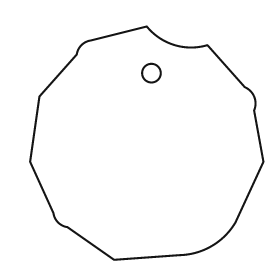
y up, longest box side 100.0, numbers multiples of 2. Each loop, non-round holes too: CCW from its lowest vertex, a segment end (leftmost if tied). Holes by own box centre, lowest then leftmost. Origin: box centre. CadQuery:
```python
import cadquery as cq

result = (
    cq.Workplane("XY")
    .moveTo(-14.0, -50.0)
    .lineTo(14.0, -48.0)
    .threePointArc((28.0, -44.0), (38.0, -34.0))
    .lineTo(50.0, -8.0)
    .lineTo(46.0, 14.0)
    .threePointArc((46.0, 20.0), (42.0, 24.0))
    .lineTo(26.0, 42.0)
    .threePointArc((12.0, 42.0), (0.0, 50.0))
    .lineTo(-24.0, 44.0)
    .threePointArc((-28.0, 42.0), (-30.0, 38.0))
    .lineTo(-46.0, 20.0)
    .lineTo(-50.0, -8.0)
    .lineTo(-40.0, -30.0)
    .threePointArc((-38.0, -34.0), (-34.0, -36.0))
    .close()
    .moveTo(2.0, 30.0)
    .circle(4.0)
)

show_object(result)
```